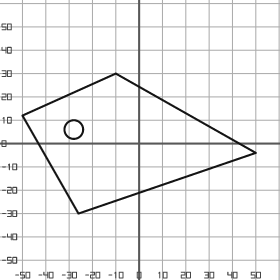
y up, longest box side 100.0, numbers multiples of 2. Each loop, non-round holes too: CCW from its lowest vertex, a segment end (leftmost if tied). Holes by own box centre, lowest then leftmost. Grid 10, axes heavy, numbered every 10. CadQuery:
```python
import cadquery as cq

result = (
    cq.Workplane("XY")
    .moveTo(-26.0, -30.0)
    .lineTo(50.0, -4.0)
    .lineTo(-10.0, 30.0)
    .lineTo(-50.0, 12.0)
    .close()
    .moveTo(-28.0, 6.0)
    .circle(4.0)
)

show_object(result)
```